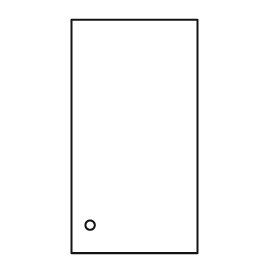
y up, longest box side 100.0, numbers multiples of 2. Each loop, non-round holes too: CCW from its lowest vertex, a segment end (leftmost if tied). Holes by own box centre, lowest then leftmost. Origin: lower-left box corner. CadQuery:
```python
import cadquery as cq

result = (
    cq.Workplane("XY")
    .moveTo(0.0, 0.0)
    .lineTo(54.0, 0.0)
    .lineTo(54.0, 100.0)
    .lineTo(0.0, 100.0)
    .close()
    .moveTo(8.0, 12.0)
    .circle(2.0)
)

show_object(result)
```